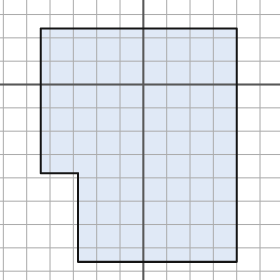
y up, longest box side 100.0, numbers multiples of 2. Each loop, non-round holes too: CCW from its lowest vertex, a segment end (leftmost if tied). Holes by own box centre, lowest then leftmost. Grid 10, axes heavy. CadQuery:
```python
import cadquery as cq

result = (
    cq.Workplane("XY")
    .moveTo(-28.0, -76.0)
    .lineTo(40.0, -76.0)
    .lineTo(40.0, 24.0)
    .lineTo(-44.0, 24.0)
    .lineTo(-44.0, -38.0)
    .lineTo(-28.0, -38.0)
    .close()
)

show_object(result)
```